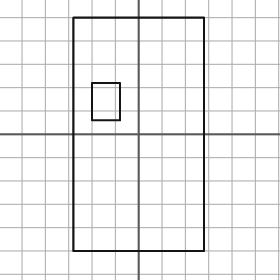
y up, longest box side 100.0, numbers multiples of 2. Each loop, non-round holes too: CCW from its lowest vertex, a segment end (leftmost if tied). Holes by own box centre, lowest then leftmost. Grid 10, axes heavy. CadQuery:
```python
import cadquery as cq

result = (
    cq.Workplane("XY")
    .moveTo(-28.0, -50.0)
    .lineTo(28.0, -50.0)
    .lineTo(28.0, 50.0)
    .lineTo(-28.0, 50.0)
    .close()
    .moveTo(-20.0, 6.0)
    .lineTo(-8.0, 6.0)
    .lineTo(-8.0, 22.0)
    .lineTo(-20.0, 22.0)
    .close()
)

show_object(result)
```